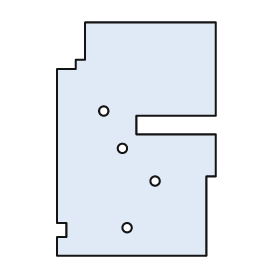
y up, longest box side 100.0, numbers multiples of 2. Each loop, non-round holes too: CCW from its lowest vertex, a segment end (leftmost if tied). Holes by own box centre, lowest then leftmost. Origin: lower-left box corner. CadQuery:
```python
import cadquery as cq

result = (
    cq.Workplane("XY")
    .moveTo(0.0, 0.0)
    .lineTo(64.0, 0.0)
    .lineTo(64.0, 34.0)
    .lineTo(68.0, 34.0)
    .lineTo(68.0, 52.0)
    .lineTo(34.0, 52.0)
    .lineTo(34.0, 60.0)
    .lineTo(68.0, 60.0)
    .lineTo(68.0, 100.0)
    .lineTo(12.0, 100.0)
    .lineTo(12.0, 84.0)
    .lineTo(8.0, 84.0)
    .lineTo(8.0, 80.0)
    .lineTo(0.0, 80.0)
    .lineTo(0.0, 14.0)
    .lineTo(4.0, 14.0)
    .lineTo(4.0, 8.0)
    .lineTo(0.0, 8.0)
    .close()
    .moveTo(30.0, 12.0)
    .circle(2.0)
    .moveTo(42.0, 32.0)
    .circle(2.0)
    .moveTo(28.0, 46.0)
    .circle(2.0)
    .moveTo(20.0, 62.0)
    .circle(2.0)
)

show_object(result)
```